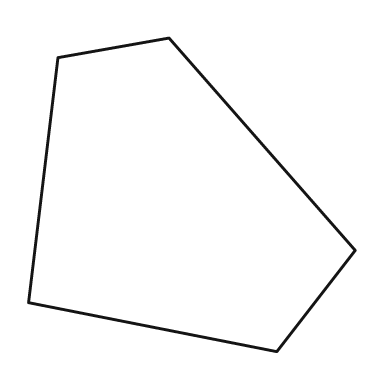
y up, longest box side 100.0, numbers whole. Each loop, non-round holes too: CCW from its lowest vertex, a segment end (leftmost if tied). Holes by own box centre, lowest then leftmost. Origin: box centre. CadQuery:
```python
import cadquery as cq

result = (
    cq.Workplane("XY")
    .moveTo(26.0, -48.0)
    .lineTo(50.0, -17.0)
    .lineTo(-7.0, 48.0)
    .lineTo(-41.0, 42.0)
    .lineTo(-50.0, -33.0)
    .close()
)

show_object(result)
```